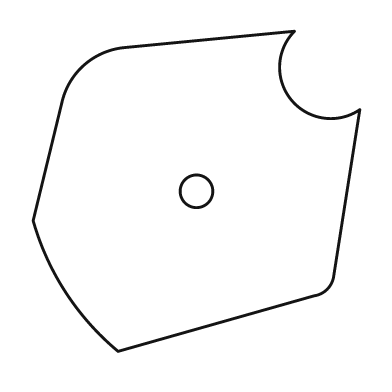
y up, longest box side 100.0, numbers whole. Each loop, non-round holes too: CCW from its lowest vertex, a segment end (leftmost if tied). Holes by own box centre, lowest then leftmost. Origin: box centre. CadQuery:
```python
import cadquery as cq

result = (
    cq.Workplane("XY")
    .moveTo(-24.0, -49.0)
    .lineTo(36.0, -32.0)
    .threePointArc((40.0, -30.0), (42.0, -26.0))
    .lineTo(50.0, 25.0)
    .threePointArc((29.0, 28.0), (30.0, 49.0))
    .lineTo(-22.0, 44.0)
    .threePointArc((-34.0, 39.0), (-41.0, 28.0))
    .lineTo(-50.0, -9.0)
    .threePointArc((-40.0, -31.0), (-24.0, -49.0))
    .close()
    .moveTo(0.0, 0.0)
    .circle(5.0)
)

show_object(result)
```